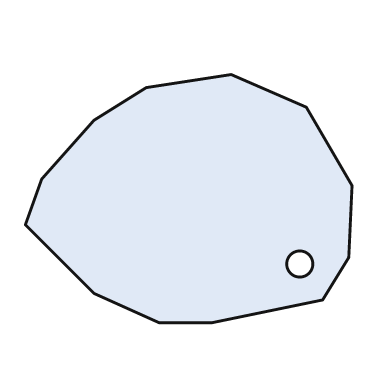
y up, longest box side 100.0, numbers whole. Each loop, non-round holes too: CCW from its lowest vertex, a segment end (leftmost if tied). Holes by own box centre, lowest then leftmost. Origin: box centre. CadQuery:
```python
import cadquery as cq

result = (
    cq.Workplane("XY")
    .moveTo(-9.0, -38.0)
    .lineTo(7.0, -38.0)
    .lineTo(41.0, -31.0)
    .lineTo(49.0, -18.0)
    .lineTo(50.0, 4.0)
    .lineTo(36.0, 28.0)
    .lineTo(13.0, 38.0)
    .lineTo(-13.0, 34.0)
    .lineTo(-29.0, 24.0)
    .lineTo(-45.0, 6.0)
    .lineTo(-50.0, -8.0)
    .lineTo(-29.0, -29.0)
    .close()
    .moveTo(34.0, -20.0)
    .circle(4.0)
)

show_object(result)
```